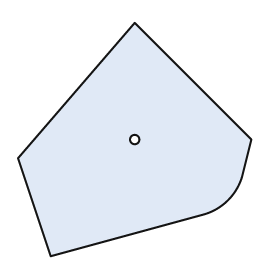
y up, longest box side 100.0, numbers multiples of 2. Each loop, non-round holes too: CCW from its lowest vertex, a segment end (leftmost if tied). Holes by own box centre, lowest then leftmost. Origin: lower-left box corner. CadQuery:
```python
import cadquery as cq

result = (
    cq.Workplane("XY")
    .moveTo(14.0, 0.0)
    .lineTo(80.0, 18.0)
    .threePointArc((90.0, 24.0), (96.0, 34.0))
    .lineTo(100.0, 50.0)
    .lineTo(50.0, 100.0)
    .lineTo(0.0, 42.0)
    .close()
    .moveTo(50.0, 50.0)
    .circle(2.0)
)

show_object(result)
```